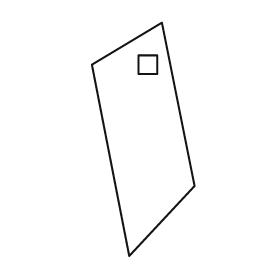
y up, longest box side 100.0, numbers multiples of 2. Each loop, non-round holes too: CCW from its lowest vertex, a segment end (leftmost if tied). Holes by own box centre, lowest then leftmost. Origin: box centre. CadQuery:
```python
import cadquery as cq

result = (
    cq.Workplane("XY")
    .moveTo(-6.0, -50.0)
    .lineTo(22.0, -20.0)
    .lineTo(8.0, 50.0)
    .lineTo(-22.0, 32.0)
    .close()
    .moveTo(-2.0, 28.0)
    .lineTo(6.0, 28.0)
    .lineTo(6.0, 36.0)
    .lineTo(-2.0, 36.0)
    .close()
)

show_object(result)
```